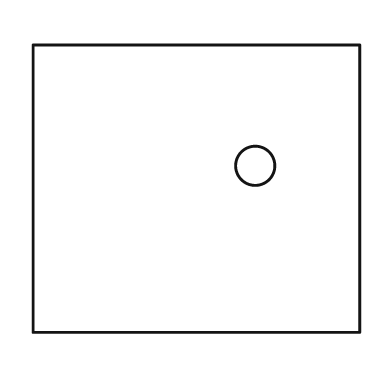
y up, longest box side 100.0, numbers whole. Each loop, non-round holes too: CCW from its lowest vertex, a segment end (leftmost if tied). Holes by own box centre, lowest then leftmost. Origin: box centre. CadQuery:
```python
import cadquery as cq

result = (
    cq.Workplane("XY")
    .moveTo(-50.0, -44.0)
    .lineTo(50.0, -44.0)
    .lineTo(50.0, 44.0)
    .lineTo(-50.0, 44.0)
    .close()
    .moveTo(18.0, 7.0)
    .circle(6.0)
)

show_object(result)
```